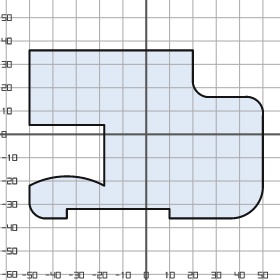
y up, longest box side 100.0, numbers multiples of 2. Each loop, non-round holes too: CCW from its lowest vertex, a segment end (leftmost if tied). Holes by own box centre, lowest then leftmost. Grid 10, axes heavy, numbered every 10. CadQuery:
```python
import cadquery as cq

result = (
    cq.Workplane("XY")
    .moveTo(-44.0, -36.0)
    .lineTo(-34.0, -36.0)
    .lineTo(-34.0, -32.0)
    .lineTo(10.0, -32.0)
    .lineTo(10.0, -36.0)
    .lineTo(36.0, -36.0)
    .threePointArc((46.0, -32.0), (50.0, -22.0))
    .lineTo(50.0, 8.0)
    .threePointArc((48.0, 14.0), (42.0, 16.0))
    .lineTo(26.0, 16.0)
    .threePointArc((22.0, 18.0), (20.0, 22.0))
    .lineTo(20.0, 36.0)
    .lineTo(-50.0, 36.0)
    .lineTo(-50.0, 4.0)
    .lineTo(-18.0, 4.0)
    .lineTo(-18.0, -22.0)
    .threePointArc((-34.0, -18.0), (-50.0, -22.0))
    .lineTo(-50.0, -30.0)
    .threePointArc((-48.0, -34.0), (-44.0, -36.0))
    .close()
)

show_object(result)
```